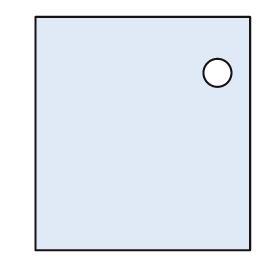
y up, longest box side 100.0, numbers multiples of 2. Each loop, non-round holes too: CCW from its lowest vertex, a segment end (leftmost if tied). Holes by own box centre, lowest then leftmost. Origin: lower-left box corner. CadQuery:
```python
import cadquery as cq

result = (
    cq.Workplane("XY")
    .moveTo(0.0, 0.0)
    .lineTo(92.0, 0.0)
    .lineTo(92.0, 100.0)
    .lineTo(0.0, 100.0)
    .close()
    .moveTo(78.0, 76.0)
    .circle(6.0)
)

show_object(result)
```